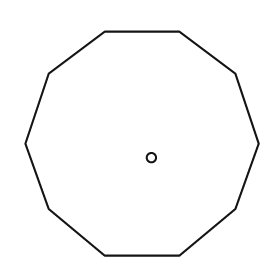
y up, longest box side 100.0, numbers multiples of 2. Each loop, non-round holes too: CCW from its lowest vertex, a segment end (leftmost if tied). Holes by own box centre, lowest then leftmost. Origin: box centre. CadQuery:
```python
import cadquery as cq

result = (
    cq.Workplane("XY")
    .moveTo(-16.0, -48.0)
    .lineTo(16.0, -48.0)
    .lineTo(40.0, -28.0)
    .lineTo(50.0, 0.0)
    .lineTo(40.0, 30.0)
    .lineTo(16.0, 48.0)
    .lineTo(-16.0, 48.0)
    .lineTo(-40.0, 30.0)
    .lineTo(-50.0, 0.0)
    .lineTo(-40.0, -28.0)
    .close()
    .moveTo(4.0, -6.0)
    .circle(2.0)
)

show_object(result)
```